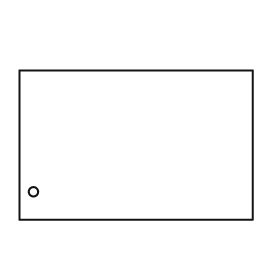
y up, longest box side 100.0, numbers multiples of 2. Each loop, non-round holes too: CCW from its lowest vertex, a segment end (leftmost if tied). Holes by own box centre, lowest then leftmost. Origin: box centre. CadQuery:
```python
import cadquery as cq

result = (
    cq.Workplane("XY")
    .moveTo(-50.0, -32.0)
    .lineTo(50.0, -32.0)
    .lineTo(50.0, 32.0)
    .lineTo(-50.0, 32.0)
    .close()
    .moveTo(-44.0, -20.0)
    .circle(2.0)
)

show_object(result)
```